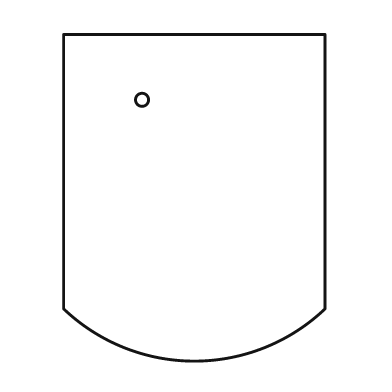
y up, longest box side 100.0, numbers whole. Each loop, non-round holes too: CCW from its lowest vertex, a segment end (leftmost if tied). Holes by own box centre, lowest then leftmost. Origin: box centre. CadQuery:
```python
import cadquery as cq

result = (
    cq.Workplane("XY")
    .moveTo(-40.0, -34.0)
    .threePointArc((0.0, -50.0), (40.0, -34.0))
    .lineTo(40.0, 50.0)
    .lineTo(-40.0, 50.0)
    .close()
    .moveTo(-16.0, 30.0)
    .circle(2.0)
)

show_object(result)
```